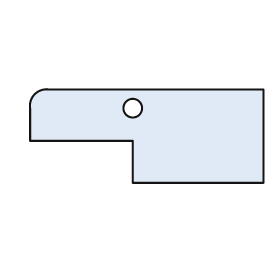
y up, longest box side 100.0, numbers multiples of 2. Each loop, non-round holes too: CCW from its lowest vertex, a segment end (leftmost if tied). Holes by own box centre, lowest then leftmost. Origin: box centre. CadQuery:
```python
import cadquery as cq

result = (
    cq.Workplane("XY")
    .moveTo(-6.0, -20.0)
    .lineTo(50.0, -20.0)
    .lineTo(50.0, 20.0)
    .lineTo(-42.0, 20.0)
    .threePointArc((-48.0, 18.0), (-50.0, 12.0))
    .lineTo(-50.0, -2.0)
    .lineTo(-6.0, -2.0)
    .close()
    .moveTo(-6.0, 12.0)
    .circle(4.0)
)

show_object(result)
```